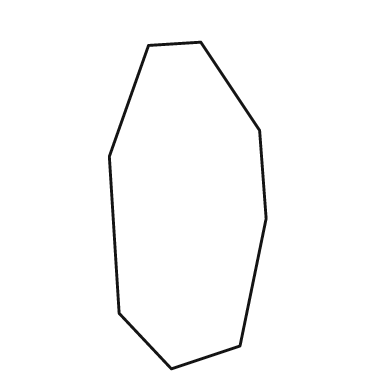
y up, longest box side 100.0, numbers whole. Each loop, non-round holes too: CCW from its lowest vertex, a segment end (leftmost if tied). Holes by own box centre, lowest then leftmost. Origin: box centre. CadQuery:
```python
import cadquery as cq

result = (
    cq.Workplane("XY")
    .moveTo(-5.0, -50.0)
    .lineTo(16.0, -43.0)
    .lineTo(24.0, -4.0)
    .lineTo(22.0, 23.0)
    .lineTo(4.0, 50.0)
    .lineTo(-12.0, 49.0)
    .lineTo(-24.0, 15.0)
    .lineTo(-21.0, -33.0)
    .close()
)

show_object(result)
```